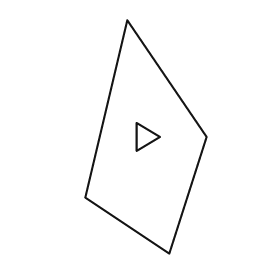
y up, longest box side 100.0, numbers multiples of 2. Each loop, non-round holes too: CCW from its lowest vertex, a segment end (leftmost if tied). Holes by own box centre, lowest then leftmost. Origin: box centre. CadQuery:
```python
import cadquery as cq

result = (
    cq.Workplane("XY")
    .moveTo(10.0, -50.0)
    .lineTo(26.0, 0.0)
    .lineTo(-8.0, 50.0)
    .lineTo(-26.0, -26.0)
    .close()
    .moveTo(-4.0, -6.0)
    .lineTo(6.0, 0.0)
    .lineTo(-4.0, 6.0)
    .close()
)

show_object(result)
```